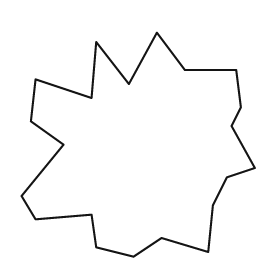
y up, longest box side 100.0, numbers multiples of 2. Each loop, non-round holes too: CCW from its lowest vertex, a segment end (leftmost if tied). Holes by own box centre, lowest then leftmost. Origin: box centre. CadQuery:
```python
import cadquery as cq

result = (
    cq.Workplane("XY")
    .moveTo(-2.0, -48.0)
    .lineTo(10.0, -40.0)
    .lineTo(30.0, -46.0)
    .lineTo(32.0, -26.0)
    .lineTo(38.0, -14.0)
    .lineTo(50.0, -10.0)
    .lineTo(40.0, 8.0)
    .lineTo(44.0, 16.0)
    .lineTo(42.0, 32.0)
    .lineTo(20.0, 32.0)
    .lineTo(8.0, 48.0)
    .lineTo(-4.0, 26.0)
    .lineTo(-18.0, 44.0)
    .lineTo(-20.0, 20.0)
    .lineTo(-44.0, 28.0)
    .lineTo(-46.0, 10.0)
    .lineTo(-32.0, 0.0)
    .lineTo(-50.0, -22.0)
    .lineTo(-44.0, -32.0)
    .lineTo(-20.0, -30.0)
    .lineTo(-18.0, -44.0)
    .close()
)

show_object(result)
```